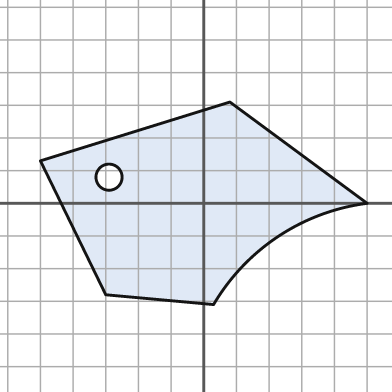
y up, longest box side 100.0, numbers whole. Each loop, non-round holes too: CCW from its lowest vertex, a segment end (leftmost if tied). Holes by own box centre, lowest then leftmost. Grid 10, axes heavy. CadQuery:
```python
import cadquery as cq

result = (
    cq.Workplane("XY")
    .moveTo(3.0, -31.0)
    .threePointArc((23.0, -10.0), (50.0, 0.0))
    .lineTo(8.0, 31.0)
    .lineTo(-50.0, 13.0)
    .lineTo(-30.0, -28.0)
    .close()
    .moveTo(-29.0, 8.0)
    .circle(4.0)
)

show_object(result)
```